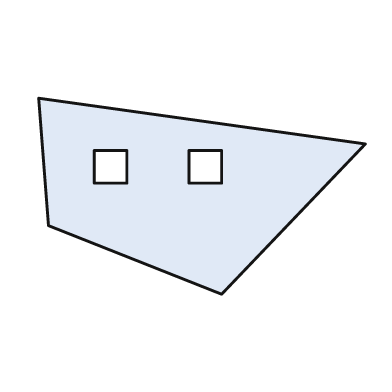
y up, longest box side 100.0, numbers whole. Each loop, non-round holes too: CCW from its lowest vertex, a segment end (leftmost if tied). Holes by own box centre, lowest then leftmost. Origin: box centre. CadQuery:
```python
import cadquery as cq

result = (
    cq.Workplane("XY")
    .moveTo(6.0, -30.0)
    .lineTo(50.0, 16.0)
    .lineTo(-50.0, 30.0)
    .lineTo(-47.0, -9.0)
    .close()
    .moveTo(-33.0, 4.0)
    .lineTo(-23.0, 4.0)
    .lineTo(-23.0, 14.0)
    .lineTo(-33.0, 14.0)
    .close()
    .moveTo(-4.0, 4.0)
    .lineTo(6.0, 4.0)
    .lineTo(6.0, 14.0)
    .lineTo(-4.0, 14.0)
    .close()
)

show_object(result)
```